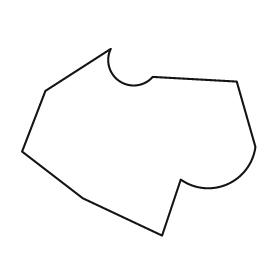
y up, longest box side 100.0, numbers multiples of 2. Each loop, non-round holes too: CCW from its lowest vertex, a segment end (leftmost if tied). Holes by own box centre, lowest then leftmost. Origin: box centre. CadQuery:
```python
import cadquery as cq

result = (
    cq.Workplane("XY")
    .moveTo(10.0, -40.0)
    .lineTo(18.0, -16.0)
    .threePointArc((38.0, -18.0), (50.0, -2.0))
    .lineTo(42.0, 26.0)
    .lineTo(6.0, 28.0)
    .threePointArc((-8.0, 26.0), (-12.0, 40.0))
    .lineTo(-40.0, 22.0)
    .lineTo(-50.0, -4.0)
    .lineTo(-24.0, -24.0)
    .close()
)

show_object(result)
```